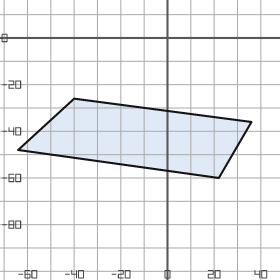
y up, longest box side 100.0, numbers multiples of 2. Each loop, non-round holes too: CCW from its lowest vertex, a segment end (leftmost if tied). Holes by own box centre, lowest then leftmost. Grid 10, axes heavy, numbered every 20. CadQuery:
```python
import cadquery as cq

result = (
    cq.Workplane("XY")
    .moveTo(22.0, -60.0)
    .lineTo(36.0, -36.0)
    .lineTo(-40.0, -26.0)
    .lineTo(-64.0, -48.0)
    .close()
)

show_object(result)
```